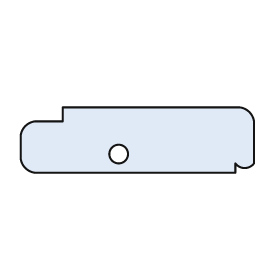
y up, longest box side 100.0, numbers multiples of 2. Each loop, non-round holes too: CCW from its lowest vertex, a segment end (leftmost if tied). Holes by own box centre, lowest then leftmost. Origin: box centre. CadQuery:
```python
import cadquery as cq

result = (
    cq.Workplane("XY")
    .moveTo(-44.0, -14.0)
    .lineTo(42.0, -14.0)
    .lineTo(42.0, -10.0)
    .threePointArc((46.0, -12.0), (50.0, -10.0))
    .lineTo(50.0, 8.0)
    .threePointArc((48.0, 12.0), (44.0, 14.0))
    .lineTo(-32.0, 14.0)
    .lineTo(-32.0, 8.0)
    .lineTo(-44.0, 8.0)
    .threePointArc((-48.0, 6.0), (-50.0, 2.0))
    .lineTo(-50.0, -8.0)
    .threePointArc((-48.0, -12.0), (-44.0, -14.0))
    .close()
    .moveTo(-8.0, -6.0)
    .circle(4.0)
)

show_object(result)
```